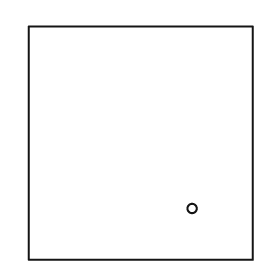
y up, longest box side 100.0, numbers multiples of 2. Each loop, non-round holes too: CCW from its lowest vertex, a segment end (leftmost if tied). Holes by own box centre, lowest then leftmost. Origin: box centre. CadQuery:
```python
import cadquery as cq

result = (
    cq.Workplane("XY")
    .moveTo(-48.0, -50.0)
    .lineTo(48.0, -50.0)
    .lineTo(48.0, 50.0)
    .lineTo(-48.0, 50.0)
    .close()
    .moveTo(22.0, -28.0)
    .circle(2.0)
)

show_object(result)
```